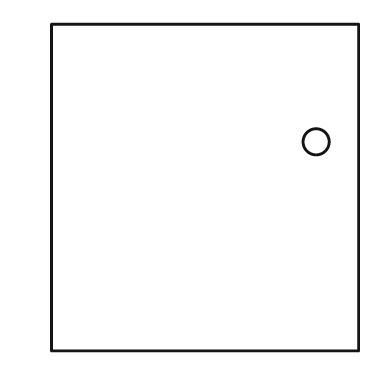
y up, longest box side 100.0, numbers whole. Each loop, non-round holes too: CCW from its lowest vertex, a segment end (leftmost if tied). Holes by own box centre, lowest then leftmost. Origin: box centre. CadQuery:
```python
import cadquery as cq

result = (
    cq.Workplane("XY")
    .moveTo(-47.0, -50.0)
    .lineTo(47.0, -50.0)
    .lineTo(47.0, 50.0)
    .lineTo(-47.0, 50.0)
    .close()
    .moveTo(34.0, 14.0)
    .circle(4.0)
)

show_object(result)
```